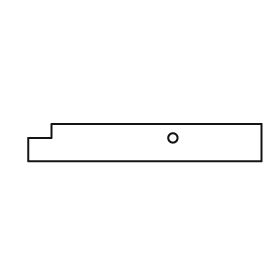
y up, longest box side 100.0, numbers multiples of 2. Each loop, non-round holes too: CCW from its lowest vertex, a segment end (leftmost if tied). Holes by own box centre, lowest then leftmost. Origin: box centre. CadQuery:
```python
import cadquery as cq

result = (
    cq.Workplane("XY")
    .moveTo(-50.0, -8.0)
    .lineTo(50.0, -8.0)
    .lineTo(50.0, 8.0)
    .lineTo(-40.0, 8.0)
    .lineTo(-40.0, 2.0)
    .lineTo(-50.0, 2.0)
    .close()
    .moveTo(12.0, 2.0)
    .circle(2.0)
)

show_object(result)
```